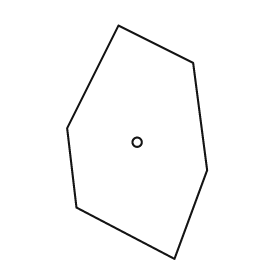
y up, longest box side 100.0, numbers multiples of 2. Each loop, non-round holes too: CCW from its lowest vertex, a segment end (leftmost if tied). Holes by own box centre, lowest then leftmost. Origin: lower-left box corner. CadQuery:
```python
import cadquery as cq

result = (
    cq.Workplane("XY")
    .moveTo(46.0, 0.0)
    .lineTo(60.0, 38.0)
    .lineTo(54.0, 84.0)
    .lineTo(22.0, 100.0)
    .lineTo(0.0, 56.0)
    .lineTo(4.0, 22.0)
    .close()
    .moveTo(30.0, 50.0)
    .circle(2.0)
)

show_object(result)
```